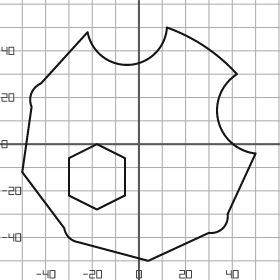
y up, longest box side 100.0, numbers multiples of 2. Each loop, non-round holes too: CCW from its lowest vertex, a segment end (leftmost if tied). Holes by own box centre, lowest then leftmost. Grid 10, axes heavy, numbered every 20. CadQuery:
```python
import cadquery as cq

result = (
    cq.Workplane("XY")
    .moveTo(4.0, -50.0)
    .lineTo(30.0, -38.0)
    .threePointArc((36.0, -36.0), (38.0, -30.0))
    .lineTo(50.0, -4.0)
    .threePointArc((34.0, 10.0), (42.0, 30.0))
    .threePointArc((28.0, 42.0), (12.0, 50.0))
    .threePointArc((-4.0, 34.0), (-22.0, 48.0))
    .lineTo(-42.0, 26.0)
    .threePointArc((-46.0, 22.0), (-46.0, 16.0))
    .lineTo(-50.0, -12.0)
    .lineTo(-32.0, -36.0)
    .threePointArc((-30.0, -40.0), (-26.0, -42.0))
    .close()
    .moveTo(-18.0, -28.0)
    .lineTo(-6.0, -22.0)
    .lineTo(-6.0, -6.0)
    .lineTo(-18.0, 0.0)
    .lineTo(-30.0, -6.0)
    .lineTo(-30.0, -22.0)
    .close()
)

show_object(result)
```